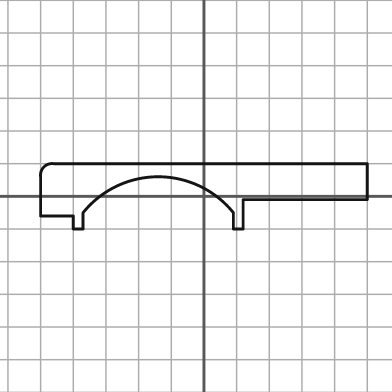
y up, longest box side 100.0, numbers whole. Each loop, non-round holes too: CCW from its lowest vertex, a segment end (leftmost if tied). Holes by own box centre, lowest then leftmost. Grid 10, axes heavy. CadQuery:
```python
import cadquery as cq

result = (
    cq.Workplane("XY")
    .moveTo(-40.0, -10.0)
    .lineTo(-37.0, -10.0)
    .lineTo(-37.0, -5.0)
    .threePointArc((-14.0, 6.0), (9.0, -5.0))
    .lineTo(9.0, -10.0)
    .lineTo(12.0, -10.0)
    .lineTo(12.0, -1.0)
    .lineTo(50.0, -1.0)
    .lineTo(50.0, 10.0)
    .lineTo(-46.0, 10.0)
    .threePointArc((-49.0, 9.0), (-50.0, 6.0))
    .lineTo(-50.0, -6.0)
    .lineTo(-40.0, -6.0)
    .close()
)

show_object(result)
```